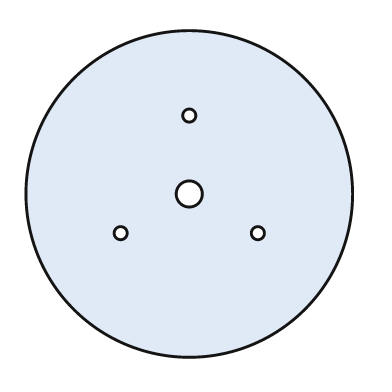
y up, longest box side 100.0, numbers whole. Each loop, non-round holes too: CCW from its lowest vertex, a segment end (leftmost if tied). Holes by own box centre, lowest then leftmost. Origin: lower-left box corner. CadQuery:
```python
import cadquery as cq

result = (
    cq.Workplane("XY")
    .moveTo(50.0, 50.0)
    .circle(50.0)
    .moveTo(29.0, 38.0)
    .circle(2.0)
    .moveTo(71.0, 38.0)
    .circle(2.0)
    .moveTo(50.0, 50.0)
    .circle(4.0)
    .moveTo(50.0, 74.0)
    .circle(2.0)
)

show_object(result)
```